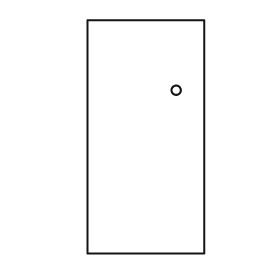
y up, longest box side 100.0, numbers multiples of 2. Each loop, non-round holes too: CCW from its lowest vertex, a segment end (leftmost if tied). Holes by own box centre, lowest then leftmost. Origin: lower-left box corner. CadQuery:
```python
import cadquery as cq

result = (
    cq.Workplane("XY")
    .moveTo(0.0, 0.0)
    .lineTo(50.0, 0.0)
    .lineTo(50.0, 100.0)
    .lineTo(0.0, 100.0)
    .close()
    .moveTo(38.0, 70.0)
    .circle(2.0)
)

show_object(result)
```